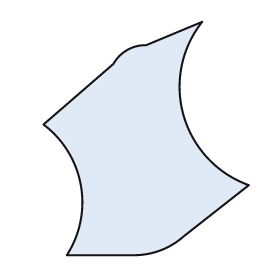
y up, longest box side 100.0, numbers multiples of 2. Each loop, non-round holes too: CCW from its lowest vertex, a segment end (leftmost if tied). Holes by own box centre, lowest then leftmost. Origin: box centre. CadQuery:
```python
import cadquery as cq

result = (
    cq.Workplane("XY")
    .moveTo(-34.0, -50.0)
    .lineTo(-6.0, -50.0)
    .threePointArc((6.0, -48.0), (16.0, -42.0))
    .lineTo(44.0, -20.0)
    .threePointArc((16.0, 10.0), (24.0, 50.0))
    .lineTo(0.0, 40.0)
    .threePointArc((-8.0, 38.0), (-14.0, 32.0))
    .lineTo(-44.0, 6.0)
    .threePointArc((-28.0, -20.0), (-34.0, -50.0))
    .close()
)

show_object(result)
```